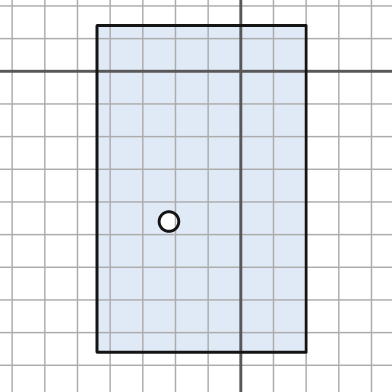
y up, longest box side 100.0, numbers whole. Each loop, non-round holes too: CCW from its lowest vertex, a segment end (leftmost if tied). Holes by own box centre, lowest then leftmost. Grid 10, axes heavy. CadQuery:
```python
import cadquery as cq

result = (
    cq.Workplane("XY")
    .moveTo(-44.0, -86.0)
    .lineTo(20.0, -86.0)
    .lineTo(20.0, 14.0)
    .lineTo(-44.0, 14.0)
    .close()
    .moveTo(-22.0, -46.0)
    .circle(3.0)
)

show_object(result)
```